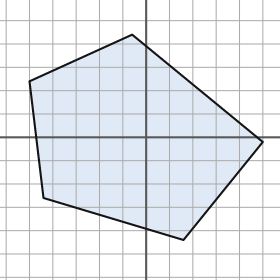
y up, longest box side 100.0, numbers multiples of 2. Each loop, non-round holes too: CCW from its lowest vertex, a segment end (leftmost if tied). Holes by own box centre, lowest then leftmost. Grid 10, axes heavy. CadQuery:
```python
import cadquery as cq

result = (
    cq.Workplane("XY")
    .moveTo(16.0, -44.0)
    .lineTo(50.0, -2.0)
    .lineTo(-6.0, 44.0)
    .lineTo(-50.0, 24.0)
    .lineTo(-44.0, -26.0)
    .close()
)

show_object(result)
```